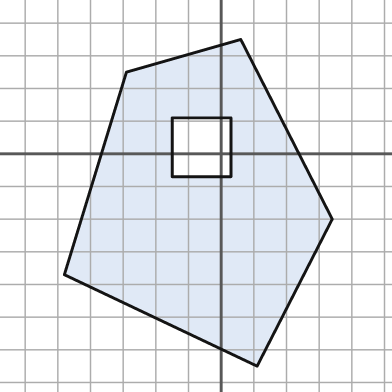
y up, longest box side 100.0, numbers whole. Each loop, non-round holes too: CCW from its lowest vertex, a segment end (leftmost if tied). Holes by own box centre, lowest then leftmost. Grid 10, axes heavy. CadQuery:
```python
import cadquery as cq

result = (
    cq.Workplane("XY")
    .moveTo(11.0, -65.0)
    .lineTo(34.0, -20.0)
    .lineTo(6.0, 35.0)
    .lineTo(-29.0, 25.0)
    .lineTo(-48.0, -37.0)
    .close()
    .moveTo(-15.0, -7.0)
    .lineTo(3.0, -7.0)
    .lineTo(3.0, 11.0)
    .lineTo(-15.0, 11.0)
    .close()
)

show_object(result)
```